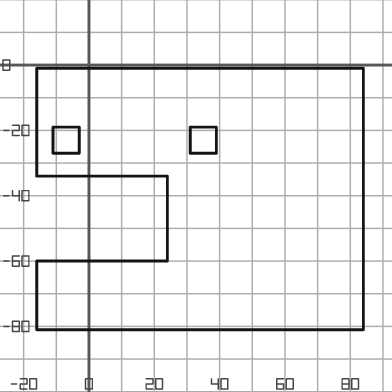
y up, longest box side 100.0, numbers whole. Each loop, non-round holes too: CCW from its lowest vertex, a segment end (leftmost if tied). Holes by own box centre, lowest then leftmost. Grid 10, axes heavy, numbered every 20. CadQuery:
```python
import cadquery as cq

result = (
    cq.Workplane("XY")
    .moveTo(-16.0, -81.0)
    .lineTo(84.0, -81.0)
    .lineTo(84.0, -1.0)
    .lineTo(-16.0, -1.0)
    .lineTo(-16.0, -34.0)
    .lineTo(24.0, -34.0)
    .lineTo(24.0, -60.0)
    .lineTo(-16.0, -60.0)
    .close()
    .moveTo(-11.0, -27.0)
    .lineTo(-3.0, -27.0)
    .lineTo(-3.0, -19.0)
    .lineTo(-11.0, -19.0)
    .close()
    .moveTo(31.0, -27.0)
    .lineTo(39.0, -27.0)
    .lineTo(39.0, -19.0)
    .lineTo(31.0, -19.0)
    .close()
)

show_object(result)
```